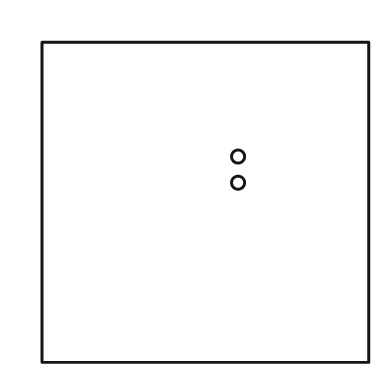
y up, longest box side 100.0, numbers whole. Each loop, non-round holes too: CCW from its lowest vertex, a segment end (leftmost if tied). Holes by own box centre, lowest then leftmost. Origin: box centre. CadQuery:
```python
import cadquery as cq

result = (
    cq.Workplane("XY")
    .moveTo(-50.0, -49.0)
    .lineTo(50.0, -49.0)
    .lineTo(50.0, 49.0)
    .lineTo(-50.0, 49.0)
    .close()
    .moveTo(10.0, 6.0)
    .circle(2.0)
    .moveTo(10.0, 14.0)
    .circle(2.0)
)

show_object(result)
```